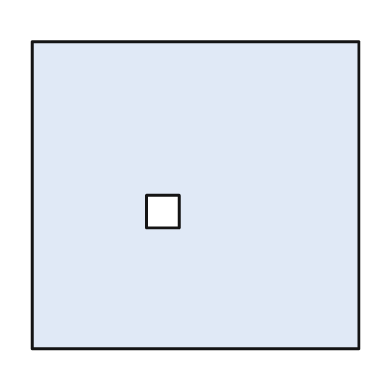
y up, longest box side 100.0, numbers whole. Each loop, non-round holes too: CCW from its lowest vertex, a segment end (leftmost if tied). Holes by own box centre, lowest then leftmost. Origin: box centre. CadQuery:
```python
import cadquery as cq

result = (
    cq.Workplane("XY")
    .moveTo(-50.0, -47.0)
    .lineTo(50.0, -47.0)
    .lineTo(50.0, 47.0)
    .lineTo(-50.0, 47.0)
    .close()
    .moveTo(-15.0, -10.0)
    .lineTo(-5.0, -10.0)
    .lineTo(-5.0, 0.0)
    .lineTo(-15.0, 0.0)
    .close()
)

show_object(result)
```